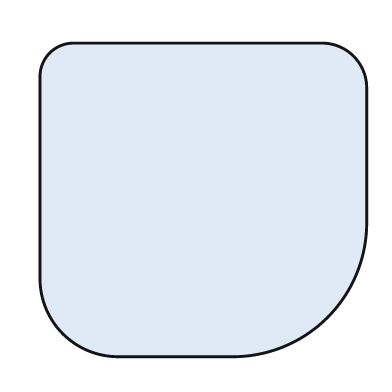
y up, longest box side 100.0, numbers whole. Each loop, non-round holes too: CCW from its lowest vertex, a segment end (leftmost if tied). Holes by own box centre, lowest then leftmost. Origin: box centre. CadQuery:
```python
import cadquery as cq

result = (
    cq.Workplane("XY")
    .moveTo(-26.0, -48.0)
    .lineTo(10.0, -48.0)
    .threePointArc((38.0, -36.0), (50.0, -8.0))
    .lineTo(50.0, 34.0)
    .threePointArc((46.0, 44.0), (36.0, 48.0))
    .lineTo(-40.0, 48.0)
    .threePointArc((-47.0, 45.0), (-50.0, 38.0))
    .lineTo(-50.0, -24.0)
    .threePointArc((-43.0, -41.0), (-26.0, -48.0))
    .close()
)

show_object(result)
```